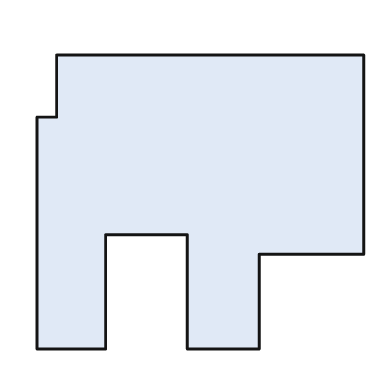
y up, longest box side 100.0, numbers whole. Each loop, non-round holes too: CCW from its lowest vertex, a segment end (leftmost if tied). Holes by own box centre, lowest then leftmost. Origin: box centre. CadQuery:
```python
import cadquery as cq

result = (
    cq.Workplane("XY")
    .moveTo(-50.0, -45.0)
    .lineTo(-29.0, -45.0)
    .lineTo(-29.0, -10.0)
    .lineTo(-4.0, -10.0)
    .lineTo(-4.0, -45.0)
    .lineTo(18.0, -45.0)
    .lineTo(18.0, -16.0)
    .lineTo(50.0, -16.0)
    .lineTo(50.0, 45.0)
    .lineTo(-44.0, 45.0)
    .lineTo(-44.0, 26.0)
    .lineTo(-50.0, 26.0)
    .close()
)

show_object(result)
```